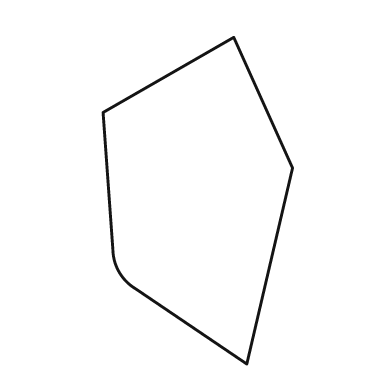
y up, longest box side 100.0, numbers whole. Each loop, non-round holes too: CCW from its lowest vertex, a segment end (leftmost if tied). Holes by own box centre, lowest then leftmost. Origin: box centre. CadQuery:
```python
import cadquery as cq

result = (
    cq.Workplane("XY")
    .moveTo(15.0, -50.0)
    .lineTo(29.0, 10.0)
    .lineTo(11.0, 50.0)
    .lineTo(-29.0, 27.0)
    .lineTo(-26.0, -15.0)
    .threePointArc((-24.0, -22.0), (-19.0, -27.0))
    .close()
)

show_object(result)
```